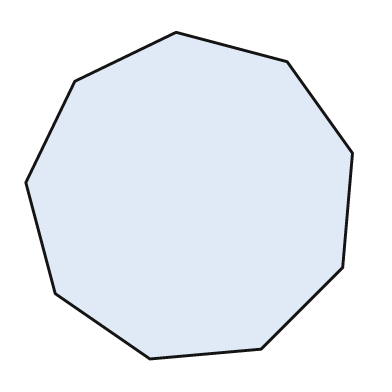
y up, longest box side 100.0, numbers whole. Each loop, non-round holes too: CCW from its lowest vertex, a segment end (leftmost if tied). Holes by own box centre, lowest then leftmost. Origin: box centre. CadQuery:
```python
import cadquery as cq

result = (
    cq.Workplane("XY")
    .moveTo(-12.0, -50.0)
    .lineTo(22.0, -47.0)
    .lineTo(47.0, -22.0)
    .lineTo(50.0, 13.0)
    .lineTo(30.0, 41.0)
    .lineTo(-4.0, 50.0)
    .lineTo(-35.0, 35.0)
    .lineTo(-50.0, 4.0)
    .lineTo(-41.0, -30.0)
    .close()
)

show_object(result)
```